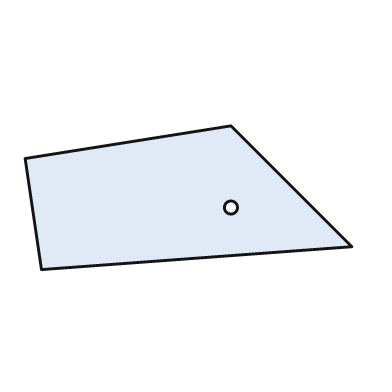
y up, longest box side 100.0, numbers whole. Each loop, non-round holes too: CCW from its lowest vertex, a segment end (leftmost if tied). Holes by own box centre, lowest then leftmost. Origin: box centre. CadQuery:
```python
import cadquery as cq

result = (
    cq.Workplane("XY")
    .moveTo(-45.0, -22.0)
    .lineTo(50.0, -15.0)
    .lineTo(13.0, 22.0)
    .lineTo(-50.0, 12.0)
    .close()
    .moveTo(13.0, -3.0)
    .circle(2.0)
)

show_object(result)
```